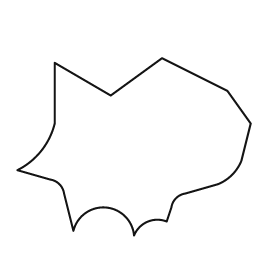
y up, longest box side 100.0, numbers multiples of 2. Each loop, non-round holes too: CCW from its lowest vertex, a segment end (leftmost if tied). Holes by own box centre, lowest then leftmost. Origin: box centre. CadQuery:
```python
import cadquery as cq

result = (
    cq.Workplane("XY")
    .moveTo(0.0, -38.0)
    .threePointArc((6.0, -32.0), (14.0, -32.0))
    .lineTo(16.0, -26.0)
    .threePointArc((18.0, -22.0), (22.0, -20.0))
    .lineTo(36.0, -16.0)
    .threePointArc((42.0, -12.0), (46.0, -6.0))
    .lineTo(50.0, 10.0)
    .lineTo(40.0, 24.0)
    .lineTo(12.0, 38.0)
    .lineTo(-10.0, 22.0)
    .lineTo(-34.0, 36.0)
    .lineTo(-34.0, 10.0)
    .threePointArc((-40.0, -2.0), (-50.0, -10.0))
    .lineTo(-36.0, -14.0)
    .threePointArc((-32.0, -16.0), (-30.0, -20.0))
    .lineTo(-26.0, -36.0)
    .threePointArc((-12.0, -26.0), (0.0, -38.0))
    .close()
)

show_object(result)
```